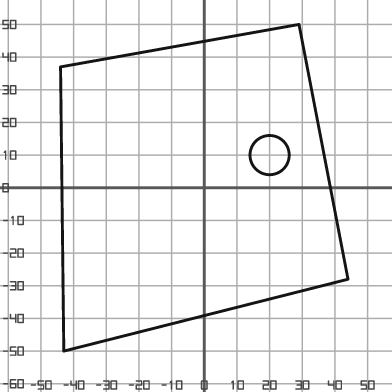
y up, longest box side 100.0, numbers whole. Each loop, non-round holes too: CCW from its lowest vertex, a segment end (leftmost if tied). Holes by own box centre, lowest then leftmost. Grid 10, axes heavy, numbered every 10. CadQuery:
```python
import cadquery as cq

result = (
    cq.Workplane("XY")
    .moveTo(-43.0, -50.0)
    .lineTo(44.0, -28.0)
    .lineTo(29.0, 50.0)
    .lineTo(-44.0, 37.0)
    .close()
    .moveTo(20.0, 10.0)
    .circle(6.0)
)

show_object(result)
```